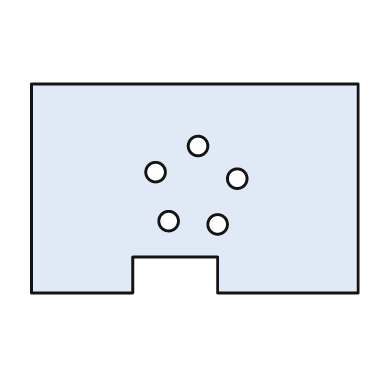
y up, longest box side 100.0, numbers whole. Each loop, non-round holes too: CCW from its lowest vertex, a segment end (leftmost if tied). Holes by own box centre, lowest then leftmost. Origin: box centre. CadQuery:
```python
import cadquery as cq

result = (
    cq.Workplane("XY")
    .moveTo(-50.0, -32.0)
    .lineTo(-19.0, -32.0)
    .lineTo(-19.0, -21.0)
    .lineTo(7.0, -21.0)
    .lineTo(7.0, -32.0)
    .lineTo(50.0, -32.0)
    .lineTo(50.0, 32.0)
    .lineTo(-50.0, 32.0)
    .close()
    .moveTo(7.0, -11.0)
    .circle(3.0)
    .moveTo(-8.0, -10.0)
    .circle(3.0)
    .moveTo(13.0, 3.0)
    .circle(3.0)
    .moveTo(-12.0, 5.0)
    .circle(3.0)
    .moveTo(1.0, 13.0)
    .circle(3.0)
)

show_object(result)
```